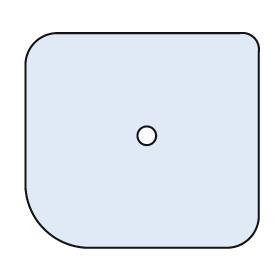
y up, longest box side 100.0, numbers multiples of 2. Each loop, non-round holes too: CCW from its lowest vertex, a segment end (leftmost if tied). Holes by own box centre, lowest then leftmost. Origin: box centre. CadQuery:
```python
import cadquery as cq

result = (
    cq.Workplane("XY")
    .moveTo(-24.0, -46.0)
    .lineTo(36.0, -46.0)
    .threePointArc((46.0, -42.0), (50.0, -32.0))
    .lineTo(50.0, 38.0)
    .threePointArc((48.0, 44.0), (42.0, 46.0))
    .lineTo(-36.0, 46.0)
    .threePointArc((-46.0, 42.0), (-50.0, 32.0))
    .lineTo(-50.0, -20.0)
    .threePointArc((-42.0, -38.0), (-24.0, -46.0))
    .close()
    .moveTo(2.0, 2.0)
    .circle(4.0)
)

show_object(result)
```